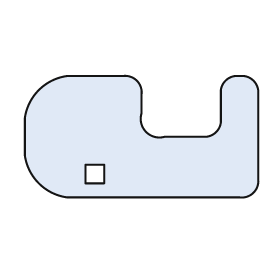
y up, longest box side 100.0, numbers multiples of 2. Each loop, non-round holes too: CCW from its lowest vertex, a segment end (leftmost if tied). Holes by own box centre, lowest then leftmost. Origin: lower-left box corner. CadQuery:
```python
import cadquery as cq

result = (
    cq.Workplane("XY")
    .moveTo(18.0, 0.0)
    .lineTo(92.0, 0.0)
    .threePointArc((98.0, 2.0), (100.0, 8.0))
    .lineTo(100.0, 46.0)
    .threePointArc((98.0, 50.0), (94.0, 52.0))
    .lineTo(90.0, 52.0)
    .threePointArc((86.0, 50.0), (84.0, 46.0))
    .lineTo(84.0, 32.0)
    .threePointArc((82.0, 28.0), (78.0, 26.0))
    .lineTo(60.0, 26.0)
    .threePointArc((52.0, 28.0), (50.0, 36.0))
    .lineTo(50.0, 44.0)
    .threePointArc((48.0, 50.0), (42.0, 52.0))
    .lineTo(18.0, 52.0)
    .threePointArc((6.0, 46.0), (0.0, 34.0))
    .lineTo(0.0, 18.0)
    .threePointArc((6.0, 6.0), (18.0, 0.0))
    .close()
    .moveTo(26.0, 6.0)
    .lineTo(34.0, 6.0)
    .lineTo(34.0, 14.0)
    .lineTo(26.0, 14.0)
    .close()
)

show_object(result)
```